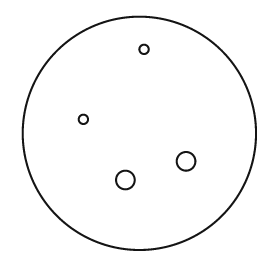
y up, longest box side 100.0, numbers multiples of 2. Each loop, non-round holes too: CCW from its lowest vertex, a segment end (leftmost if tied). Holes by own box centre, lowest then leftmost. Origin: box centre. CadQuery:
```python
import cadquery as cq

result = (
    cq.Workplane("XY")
    .moveTo(0.0, 0.0)
    .circle(50.0)
    .moveTo(-6.0, -20.0)
    .circle(4.0)
    .moveTo(20.0, -12.0)
    .circle(4.0)
    .moveTo(-24.0, 6.0)
    .circle(2.0)
    .moveTo(2.0, 36.0)
    .circle(2.0)
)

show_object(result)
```